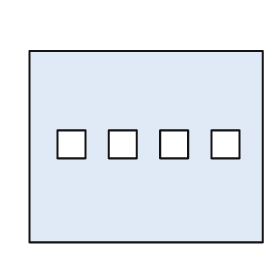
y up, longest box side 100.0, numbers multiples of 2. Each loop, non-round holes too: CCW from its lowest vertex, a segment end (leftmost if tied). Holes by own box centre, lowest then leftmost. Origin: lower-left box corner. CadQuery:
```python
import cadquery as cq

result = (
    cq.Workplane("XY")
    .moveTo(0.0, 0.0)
    .lineTo(100.0, 0.0)
    .lineTo(100.0, 82.0)
    .lineTo(0.0, 82.0)
    .close()
    .moveTo(12.0, 36.0)
    .lineTo(24.0, 36.0)
    .lineTo(24.0, 48.0)
    .lineTo(12.0, 48.0)
    .close()
    .moveTo(34.0, 36.0)
    .lineTo(46.0, 36.0)
    .lineTo(46.0, 48.0)
    .lineTo(34.0, 48.0)
    .close()
    .moveTo(56.0, 36.0)
    .lineTo(68.0, 36.0)
    .lineTo(68.0, 48.0)
    .lineTo(56.0, 48.0)
    .close()
    .moveTo(78.0, 36.0)
    .lineTo(90.0, 36.0)
    .lineTo(90.0, 48.0)
    .lineTo(78.0, 48.0)
    .close()
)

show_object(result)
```